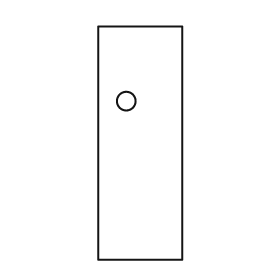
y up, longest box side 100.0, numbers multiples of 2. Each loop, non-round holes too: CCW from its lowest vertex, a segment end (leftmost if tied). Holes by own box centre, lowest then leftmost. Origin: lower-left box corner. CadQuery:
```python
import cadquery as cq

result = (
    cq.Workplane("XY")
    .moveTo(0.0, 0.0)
    .lineTo(36.0, 0.0)
    .lineTo(36.0, 100.0)
    .lineTo(0.0, 100.0)
    .close()
    .moveTo(12.0, 68.0)
    .circle(4.0)
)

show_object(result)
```